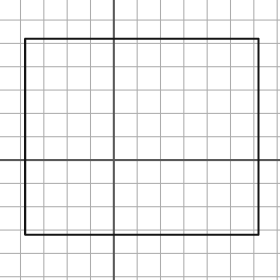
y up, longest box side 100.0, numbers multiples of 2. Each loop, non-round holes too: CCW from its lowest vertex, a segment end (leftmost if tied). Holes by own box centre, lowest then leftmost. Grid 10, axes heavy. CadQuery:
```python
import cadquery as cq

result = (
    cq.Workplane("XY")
    .moveTo(-38.0, -32.0)
    .lineTo(62.0, -32.0)
    .lineTo(62.0, 52.0)
    .lineTo(-38.0, 52.0)
    .close()
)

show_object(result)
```